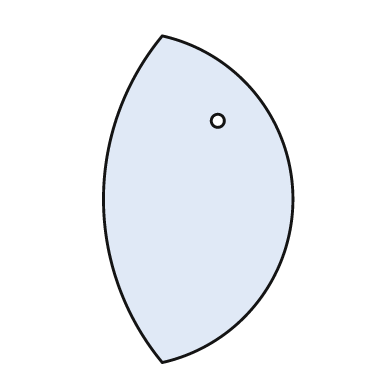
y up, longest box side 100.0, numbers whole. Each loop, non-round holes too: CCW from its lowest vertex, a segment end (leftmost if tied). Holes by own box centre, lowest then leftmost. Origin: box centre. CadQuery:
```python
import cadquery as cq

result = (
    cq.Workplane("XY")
    .moveTo(-11.0, -50.0)
    .threePointArc((29.0, 0.0), (-11.0, 50.0))
    .threePointArc((-29.0, 0.0), (-11.0, -50.0))
    .close()
    .moveTo(6.0, 24.0)
    .circle(2.0)
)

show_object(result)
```